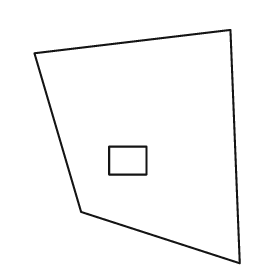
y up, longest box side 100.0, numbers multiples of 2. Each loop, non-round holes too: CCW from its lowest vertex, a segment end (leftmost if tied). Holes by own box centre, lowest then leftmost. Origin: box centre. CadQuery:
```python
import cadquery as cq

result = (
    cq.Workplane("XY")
    .moveTo(44.0, -50.0)
    .lineTo(40.0, 50.0)
    .lineTo(-44.0, 40.0)
    .lineTo(-24.0, -28.0)
    .close()
    .moveTo(-12.0, -12.0)
    .lineTo(4.0, -12.0)
    .lineTo(4.0, 0.0)
    .lineTo(-12.0, 0.0)
    .close()
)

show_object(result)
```